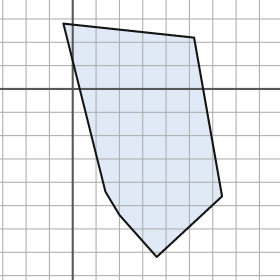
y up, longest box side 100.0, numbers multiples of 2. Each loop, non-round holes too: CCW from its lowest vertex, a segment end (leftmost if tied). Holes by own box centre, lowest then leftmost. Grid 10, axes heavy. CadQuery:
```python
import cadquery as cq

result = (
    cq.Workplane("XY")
    .moveTo(36.0, -72.0)
    .lineTo(64.0, -46.0)
    .lineTo(52.0, 22.0)
    .lineTo(-4.0, 28.0)
    .lineTo(14.0, -44.0)
    .lineTo(20.0, -54.0)
    .close()
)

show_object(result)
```